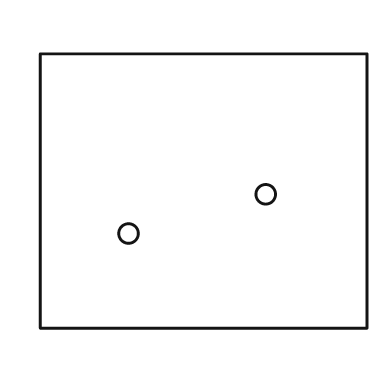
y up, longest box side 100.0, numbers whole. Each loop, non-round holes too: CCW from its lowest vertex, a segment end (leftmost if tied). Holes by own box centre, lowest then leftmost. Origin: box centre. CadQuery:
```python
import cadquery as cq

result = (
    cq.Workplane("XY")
    .moveTo(-50.0, -42.0)
    .lineTo(50.0, -42.0)
    .lineTo(50.0, 42.0)
    .lineTo(-50.0, 42.0)
    .close()
    .moveTo(-23.0, -13.0)
    .circle(3.0)
    .moveTo(19.0, -1.0)
    .circle(3.0)
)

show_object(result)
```